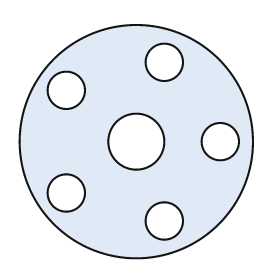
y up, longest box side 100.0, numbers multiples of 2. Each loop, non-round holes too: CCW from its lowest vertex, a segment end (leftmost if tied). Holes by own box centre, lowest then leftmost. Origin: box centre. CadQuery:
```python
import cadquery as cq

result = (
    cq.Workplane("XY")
    .moveTo(0.0, 0.0)
    .circle(50.0)
    .moveTo(12.0, -34.0)
    .circle(8.0)
    .moveTo(-30.0, -22.0)
    .circle(8.0)
    .moveTo(0.0, 0.0)
    .circle(12.0)
    .moveTo(36.0, 0.0)
    .circle(8.0)
    .moveTo(-30.0, 22.0)
    .circle(8.0)
    .moveTo(12.0, 34.0)
    .circle(8.0)
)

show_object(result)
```